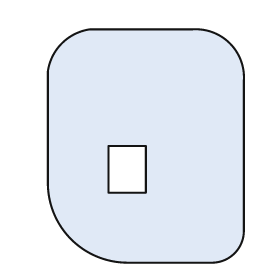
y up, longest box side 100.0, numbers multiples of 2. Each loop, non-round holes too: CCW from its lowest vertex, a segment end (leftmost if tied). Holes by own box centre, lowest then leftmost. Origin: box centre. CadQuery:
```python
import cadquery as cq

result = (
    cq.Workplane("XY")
    .moveTo(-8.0, -50.0)
    .lineTo(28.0, -50.0)
    .threePointArc((38.0, -46.0), (42.0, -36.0))
    .lineTo(42.0, 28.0)
    .threePointArc((36.0, 44.0), (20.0, 50.0))
    .lineTo(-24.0, 50.0)
    .threePointArc((-36.0, 44.0), (-42.0, 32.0))
    .lineTo(-42.0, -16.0)
    .threePointArc((-32.0, -40.0), (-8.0, -50.0))
    .close()
    .moveTo(-16.0, -20.0)
    .lineTo(0.0, -20.0)
    .lineTo(0.0, 0.0)
    .lineTo(-16.0, 0.0)
    .close()
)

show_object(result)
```